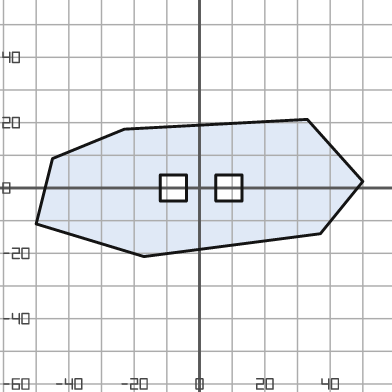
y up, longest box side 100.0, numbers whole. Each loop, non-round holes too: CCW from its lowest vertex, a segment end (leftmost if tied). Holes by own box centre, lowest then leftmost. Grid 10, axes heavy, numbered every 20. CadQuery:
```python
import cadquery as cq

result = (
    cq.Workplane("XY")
    .moveTo(-17.0, -21.0)
    .lineTo(37.0, -14.0)
    .lineTo(50.0, 2.0)
    .lineTo(33.0, 21.0)
    .lineTo(-23.0, 18.0)
    .lineTo(-45.0, 9.0)
    .lineTo(-50.0, -11.0)
    .close()
    .moveTo(-12.0, -4.0)
    .lineTo(-4.0, -4.0)
    .lineTo(-4.0, 4.0)
    .lineTo(-12.0, 4.0)
    .close()
    .moveTo(5.0, -4.0)
    .lineTo(13.0, -4.0)
    .lineTo(13.0, 4.0)
    .lineTo(5.0, 4.0)
    .close()
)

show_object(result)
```